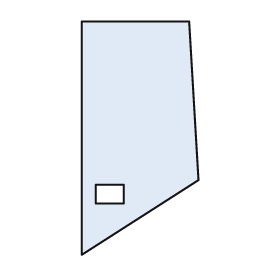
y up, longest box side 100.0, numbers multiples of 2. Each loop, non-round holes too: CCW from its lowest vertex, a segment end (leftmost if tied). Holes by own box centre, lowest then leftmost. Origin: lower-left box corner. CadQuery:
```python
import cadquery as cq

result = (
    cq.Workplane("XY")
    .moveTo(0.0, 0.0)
    .lineTo(50.0, 32.0)
    .lineTo(46.0, 100.0)
    .lineTo(0.0, 100.0)
    .close()
    .moveTo(6.0, 22.0)
    .lineTo(18.0, 22.0)
    .lineTo(18.0, 30.0)
    .lineTo(6.0, 30.0)
    .close()
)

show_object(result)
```